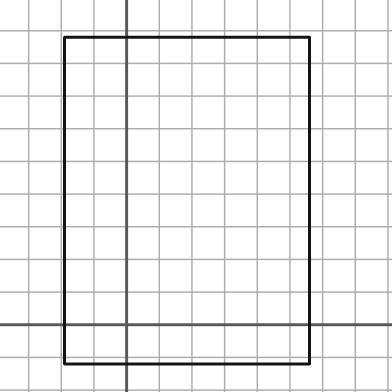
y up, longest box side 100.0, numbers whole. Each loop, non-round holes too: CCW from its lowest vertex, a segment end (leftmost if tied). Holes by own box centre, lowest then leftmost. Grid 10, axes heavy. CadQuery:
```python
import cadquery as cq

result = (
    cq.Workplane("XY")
    .moveTo(-19.0, -12.0)
    .lineTo(56.0, -12.0)
    .lineTo(56.0, 88.0)
    .lineTo(-19.0, 88.0)
    .close()
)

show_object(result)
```